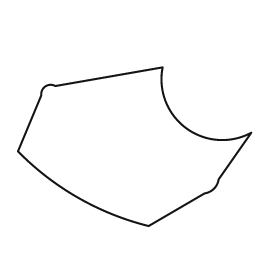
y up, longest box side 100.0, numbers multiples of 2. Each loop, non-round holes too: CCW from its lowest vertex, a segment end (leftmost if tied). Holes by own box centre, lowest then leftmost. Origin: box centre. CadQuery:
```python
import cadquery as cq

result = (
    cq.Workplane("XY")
    .moveTo(6.0, -34.0)
    .lineTo(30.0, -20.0)
    .threePointArc((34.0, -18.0), (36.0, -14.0))
    .lineTo(50.0, 6.0)
    .threePointArc((22.0, 8.0), (12.0, 34.0))
    .lineTo(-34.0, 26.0)
    .threePointArc((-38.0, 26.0), (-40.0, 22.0))
    .lineTo(-50.0, -2.0)
    .threePointArc((-24.0, -22.0), (6.0, -34.0))
    .close()
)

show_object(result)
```